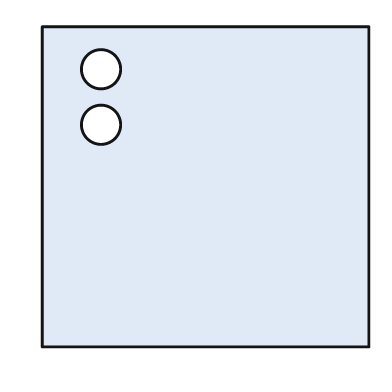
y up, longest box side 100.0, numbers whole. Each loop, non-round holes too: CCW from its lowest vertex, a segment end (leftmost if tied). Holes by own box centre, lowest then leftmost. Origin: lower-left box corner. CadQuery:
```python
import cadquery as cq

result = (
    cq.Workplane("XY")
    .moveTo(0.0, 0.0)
    .lineTo(100.0, 0.0)
    .lineTo(100.0, 98.0)
    .lineTo(0.0, 98.0)
    .close()
    .moveTo(18.0, 68.0)
    .circle(6.0)
    .moveTo(18.0, 85.0)
    .circle(6.0)
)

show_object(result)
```